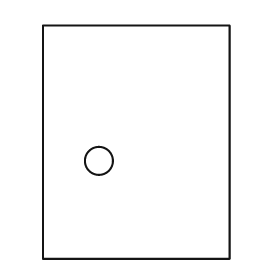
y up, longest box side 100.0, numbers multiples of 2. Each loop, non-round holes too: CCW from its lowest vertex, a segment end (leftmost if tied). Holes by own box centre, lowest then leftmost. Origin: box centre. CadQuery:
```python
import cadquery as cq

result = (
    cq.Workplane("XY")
    .moveTo(-40.0, -50.0)
    .lineTo(40.0, -50.0)
    .lineTo(40.0, 50.0)
    .lineTo(-40.0, 50.0)
    .close()
    .moveTo(-16.0, -8.0)
    .circle(6.0)
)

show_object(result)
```